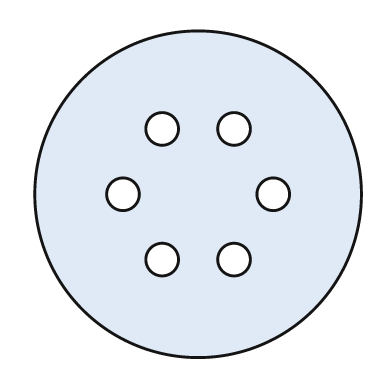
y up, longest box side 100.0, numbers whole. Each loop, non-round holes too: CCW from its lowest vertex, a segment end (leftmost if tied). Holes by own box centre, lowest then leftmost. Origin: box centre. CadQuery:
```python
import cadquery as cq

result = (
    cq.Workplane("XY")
    .moveTo(0.0, 0.0)
    .circle(50.0)
    .moveTo(-11.0, -20.0)
    .circle(5.0)
    .moveTo(11.0, -20.0)
    .circle(5.0)
    .moveTo(-23.0, 0.0)
    .circle(5.0)
    .moveTo(23.0, 0.0)
    .circle(5.0)
    .moveTo(-11.0, 20.0)
    .circle(5.0)
    .moveTo(11.0, 20.0)
    .circle(5.0)
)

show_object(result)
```